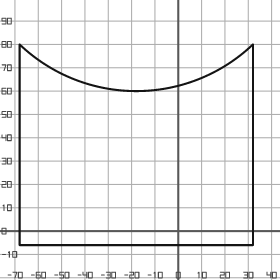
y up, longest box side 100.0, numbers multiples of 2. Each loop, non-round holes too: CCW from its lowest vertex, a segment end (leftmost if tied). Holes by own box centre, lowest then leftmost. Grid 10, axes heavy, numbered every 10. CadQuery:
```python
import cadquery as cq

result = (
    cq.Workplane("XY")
    .moveTo(-68.0, -6.0)
    .lineTo(32.0, -6.0)
    .lineTo(32.0, 80.0)
    .threePointArc((-18.0, 60.0), (-68.0, 80.0))
    .close()
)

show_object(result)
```